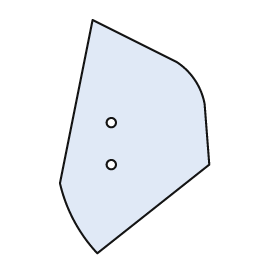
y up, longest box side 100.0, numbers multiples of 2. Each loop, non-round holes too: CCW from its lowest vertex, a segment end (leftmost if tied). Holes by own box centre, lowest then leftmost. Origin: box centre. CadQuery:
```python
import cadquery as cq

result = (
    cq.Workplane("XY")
    .moveTo(-16.0, -50.0)
    .lineTo(32.0, -12.0)
    .lineTo(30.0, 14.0)
    .threePointArc((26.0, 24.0), (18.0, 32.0))
    .lineTo(-18.0, 50.0)
    .lineTo(-32.0, -20.0)
    .threePointArc((-26.0, -36.0), (-16.0, -50.0))
    .close()
    .moveTo(-10.0, -12.0)
    .circle(2.0)
    .moveTo(-10.0, 6.0)
    .circle(2.0)
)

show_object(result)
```